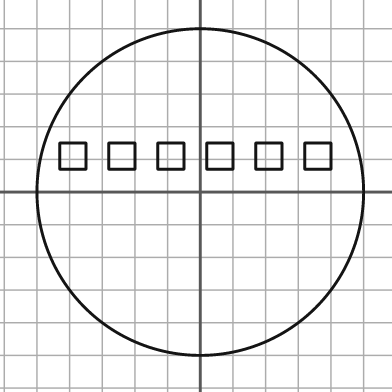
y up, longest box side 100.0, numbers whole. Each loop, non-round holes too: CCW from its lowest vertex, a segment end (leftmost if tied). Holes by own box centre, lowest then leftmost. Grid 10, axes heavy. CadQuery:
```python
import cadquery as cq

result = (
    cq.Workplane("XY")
    .moveTo(0.0, 0.0)
    .circle(50.0)
    .moveTo(-43.0, 7.0)
    .lineTo(-35.0, 7.0)
    .lineTo(-35.0, 15.0)
    .lineTo(-43.0, 15.0)
    .close()
    .moveTo(-28.0, 7.0)
    .lineTo(-20.0, 7.0)
    .lineTo(-20.0, 15.0)
    .lineTo(-28.0, 15.0)
    .close()
    .moveTo(-13.0, 7.0)
    .lineTo(-5.0, 7.0)
    .lineTo(-5.0, 15.0)
    .lineTo(-13.0, 15.0)
    .close()
    .moveTo(2.0, 7.0)
    .lineTo(10.0, 7.0)
    .lineTo(10.0, 15.0)
    .lineTo(2.0, 15.0)
    .close()
    .moveTo(17.0, 7.0)
    .lineTo(25.0, 7.0)
    .lineTo(25.0, 15.0)
    .lineTo(17.0, 15.0)
    .close()
    .moveTo(32.0, 7.0)
    .lineTo(40.0, 7.0)
    .lineTo(40.0, 15.0)
    .lineTo(32.0, 15.0)
    .close()
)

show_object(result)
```